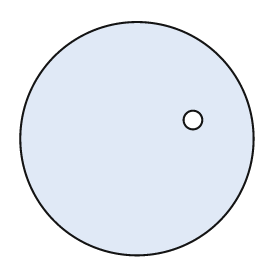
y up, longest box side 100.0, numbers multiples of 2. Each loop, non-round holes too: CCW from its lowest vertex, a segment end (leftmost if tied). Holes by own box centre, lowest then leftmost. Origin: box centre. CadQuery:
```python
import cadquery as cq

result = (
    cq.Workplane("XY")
    .moveTo(0.0, 0.0)
    .circle(50.0)
    .moveTo(24.0, 8.0)
    .circle(4.0)
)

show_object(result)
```